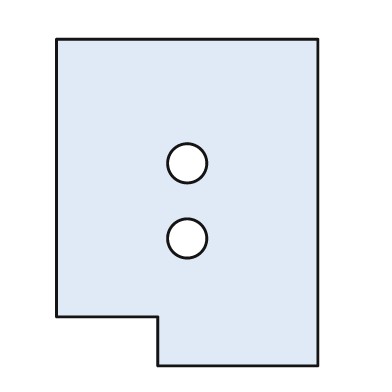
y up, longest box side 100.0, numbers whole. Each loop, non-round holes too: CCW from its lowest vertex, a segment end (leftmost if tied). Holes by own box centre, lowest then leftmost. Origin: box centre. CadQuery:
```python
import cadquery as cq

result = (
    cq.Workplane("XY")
    .moveTo(-9.0, -50.0)
    .lineTo(40.0, -50.0)
    .lineTo(40.0, 50.0)
    .lineTo(-40.0, 50.0)
    .lineTo(-40.0, -35.0)
    .lineTo(-9.0, -35.0)
    .close()
    .moveTo(0.0, -11.0)
    .circle(6.0)
    .moveTo(0.0, 12.0)
    .circle(6.0)
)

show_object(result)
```